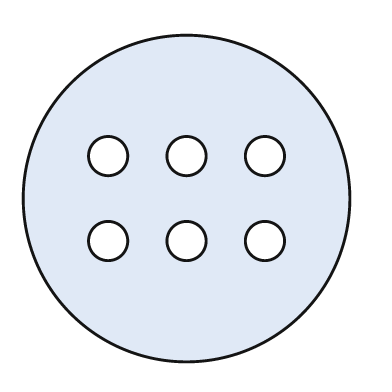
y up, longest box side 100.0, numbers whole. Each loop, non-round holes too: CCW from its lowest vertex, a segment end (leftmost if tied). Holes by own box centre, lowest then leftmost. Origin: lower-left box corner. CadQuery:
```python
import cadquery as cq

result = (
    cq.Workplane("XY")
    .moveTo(50.0, 50.0)
    .circle(50.0)
    .moveTo(26.0, 37.0)
    .circle(6.0)
    .moveTo(50.0, 37.0)
    .circle(6.0)
    .moveTo(74.0, 37.0)
    .circle(6.0)
    .moveTo(26.0, 63.0)
    .circle(6.0)
    .moveTo(50.0, 63.0)
    .circle(6.0)
    .moveTo(74.0, 63.0)
    .circle(6.0)
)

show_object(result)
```